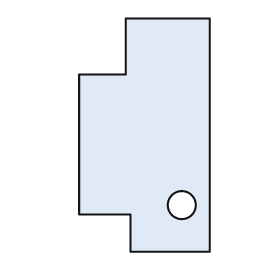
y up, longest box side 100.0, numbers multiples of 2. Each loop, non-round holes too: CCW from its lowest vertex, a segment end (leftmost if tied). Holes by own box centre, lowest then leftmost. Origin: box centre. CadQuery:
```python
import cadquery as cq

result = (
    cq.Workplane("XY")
    .moveTo(-6.0, -50.0)
    .lineTo(28.0, -50.0)
    .lineTo(28.0, 50.0)
    .lineTo(-8.0, 50.0)
    .lineTo(-8.0, 26.0)
    .lineTo(-28.0, 26.0)
    .lineTo(-28.0, -34.0)
    .lineTo(-6.0, -34.0)
    .close()
    .moveTo(16.0, -30.0)
    .circle(6.0)
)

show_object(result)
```